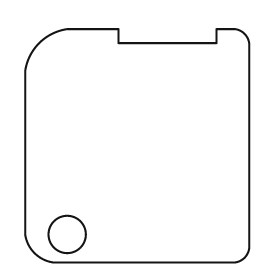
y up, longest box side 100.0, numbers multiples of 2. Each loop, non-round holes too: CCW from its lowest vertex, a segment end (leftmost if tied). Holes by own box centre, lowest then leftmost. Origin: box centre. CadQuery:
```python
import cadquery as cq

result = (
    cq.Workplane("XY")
    .moveTo(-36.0, -50.0)
    .lineTo(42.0, -50.0)
    .threePointArc((46.0, -48.0), (48.0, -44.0))
    .lineTo(48.0, 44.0)
    .threePointArc((46.0, 48.0), (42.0, 50.0))
    .lineTo(34.0, 50.0)
    .lineTo(34.0, 44.0)
    .lineTo(-8.0, 44.0)
    .lineTo(-8.0, 50.0)
    .lineTo(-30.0, 50.0)
    .threePointArc((-42.0, 44.0), (-48.0, 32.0))
    .lineTo(-48.0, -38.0)
    .threePointArc((-44.0, -46.0), (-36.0, -50.0))
    .close()
    .moveTo(-30.0, -38.0)
    .circle(8.0)
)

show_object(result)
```